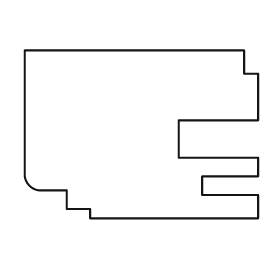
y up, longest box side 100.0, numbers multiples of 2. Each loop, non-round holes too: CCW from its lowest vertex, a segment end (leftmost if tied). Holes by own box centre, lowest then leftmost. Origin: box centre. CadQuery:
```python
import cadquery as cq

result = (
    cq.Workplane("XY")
    .moveTo(-22.0, -36.0)
    .lineTo(50.0, -36.0)
    .lineTo(50.0, -26.0)
    .lineTo(26.0, -26.0)
    .lineTo(26.0, -18.0)
    .lineTo(50.0, -18.0)
    .lineTo(50.0, -10.0)
    .lineTo(16.0, -10.0)
    .lineTo(16.0, 6.0)
    .lineTo(50.0, 6.0)
    .lineTo(50.0, 26.0)
    .lineTo(44.0, 26.0)
    .lineTo(44.0, 36.0)
    .lineTo(-50.0, 36.0)
    .lineTo(-50.0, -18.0)
    .threePointArc((-48.0, -22.0), (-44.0, -24.0))
    .lineTo(-32.0, -24.0)
    .lineTo(-32.0, -32.0)
    .lineTo(-22.0, -32.0)
    .close()
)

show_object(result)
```